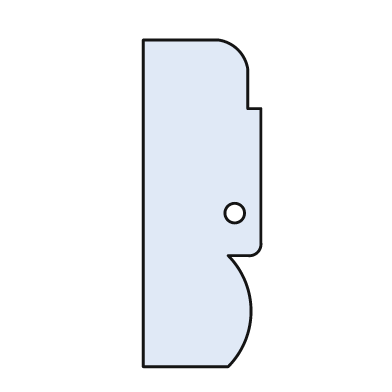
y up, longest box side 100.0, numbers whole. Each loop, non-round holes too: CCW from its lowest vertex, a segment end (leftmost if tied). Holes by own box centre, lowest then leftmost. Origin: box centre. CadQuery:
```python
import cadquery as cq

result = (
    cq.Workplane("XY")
    .moveTo(-18.0, -50.0)
    .lineTo(8.0, -50.0)
    .threePointArc((15.0, -33.0), (8.0, -16.0))
    .lineTo(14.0, -16.0)
    .threePointArc((17.0, -15.0), (18.0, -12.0))
    .lineTo(18.0, 29.0)
    .lineTo(14.0, 29.0)
    .lineTo(14.0, 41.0)
    .threePointArc((11.0, 47.0), (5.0, 50.0))
    .lineTo(-18.0, 50.0)
    .close()
    .moveTo(10.0, -3.0)
    .circle(3.0)
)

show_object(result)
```